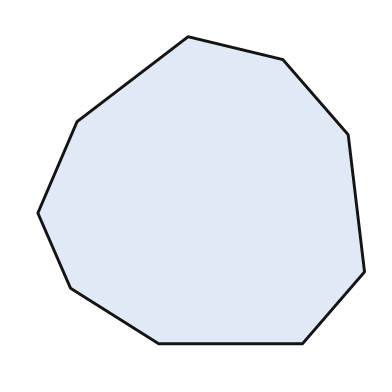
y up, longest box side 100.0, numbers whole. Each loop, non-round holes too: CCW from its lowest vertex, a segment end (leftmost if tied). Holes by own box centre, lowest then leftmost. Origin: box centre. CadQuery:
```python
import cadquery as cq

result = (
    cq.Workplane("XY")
    .moveTo(-13.0, -47.0)
    .lineTo(31.0, -47.0)
    .lineTo(50.0, -25.0)
    .lineTo(45.0, 17.0)
    .lineTo(25.0, 40.0)
    .lineTo(-4.0, 47.0)
    .lineTo(-38.0, 21.0)
    .lineTo(-50.0, -7.0)
    .lineTo(-40.0, -30.0)
    .close()
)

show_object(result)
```